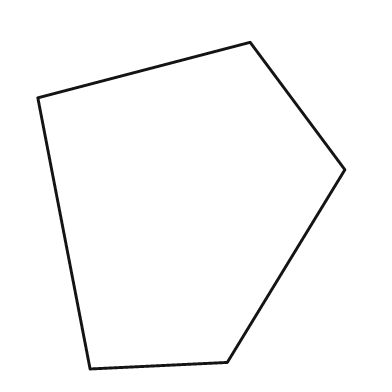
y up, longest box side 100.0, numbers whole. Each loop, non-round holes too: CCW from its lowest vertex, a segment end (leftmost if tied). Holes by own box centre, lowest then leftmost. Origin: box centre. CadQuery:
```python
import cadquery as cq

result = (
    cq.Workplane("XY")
    .moveTo(-31.0, -50.0)
    .lineTo(11.0, -48.0)
    .lineTo(47.0, 11.0)
    .lineTo(18.0, 50.0)
    .lineTo(-47.0, 33.0)
    .close()
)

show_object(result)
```